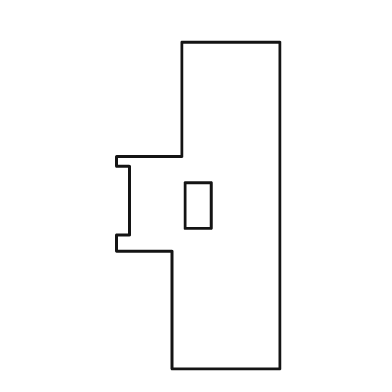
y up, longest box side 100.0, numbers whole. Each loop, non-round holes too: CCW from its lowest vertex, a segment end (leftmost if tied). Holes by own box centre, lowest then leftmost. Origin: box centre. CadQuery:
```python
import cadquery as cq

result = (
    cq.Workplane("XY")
    .moveTo(-8.0, -50.0)
    .lineTo(25.0, -50.0)
    .lineTo(25.0, 50.0)
    .lineTo(-5.0, 50.0)
    .lineTo(-5.0, 15.0)
    .lineTo(-25.0, 15.0)
    .lineTo(-25.0, 12.0)
    .lineTo(-21.0, 12.0)
    .lineTo(-21.0, -9.0)
    .lineTo(-25.0, -9.0)
    .lineTo(-25.0, -14.0)
    .lineTo(-8.0, -14.0)
    .close()
    .moveTo(-4.0, -7.0)
    .lineTo(4.0, -7.0)
    .lineTo(4.0, 7.0)
    .lineTo(-4.0, 7.0)
    .close()
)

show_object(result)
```